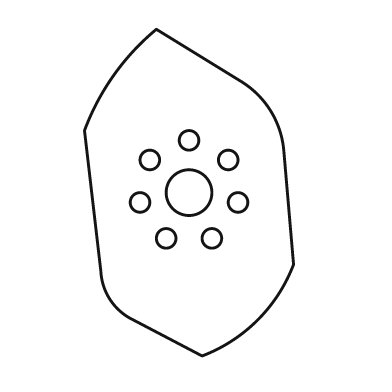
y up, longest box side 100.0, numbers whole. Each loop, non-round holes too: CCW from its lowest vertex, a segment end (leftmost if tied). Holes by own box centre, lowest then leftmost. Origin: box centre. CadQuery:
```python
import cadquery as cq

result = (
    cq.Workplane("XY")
    .moveTo(4.0, -50.0)
    .threePointArc((21.0, -39.0), (32.0, -22.0))
    .lineTo(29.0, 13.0)
    .threePointArc((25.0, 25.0), (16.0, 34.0))
    .lineTo(-10.0, 50.0)
    .threePointArc((-23.0, 36.0), (-32.0, 19.0))
    .lineTo(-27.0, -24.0)
    .threePointArc((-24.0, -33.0), (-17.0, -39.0))
    .close()
    .moveTo(-7.0, -14.0)
    .circle(3.0)
    .moveTo(7.0, -14.0)
    .circle(3.0)
    .moveTo(-15.0, -3.0)
    .circle(3.0)
    .moveTo(15.0, -3.0)
    .circle(3.0)
    .moveTo(0.0, 0.0)
    .circle(7.0)
    .moveTo(-12.0, 10.0)
    .circle(3.0)
    .moveTo(12.0, 10.0)
    .circle(3.0)
    .moveTo(0.0, 16.0)
    .circle(3.0)
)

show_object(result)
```